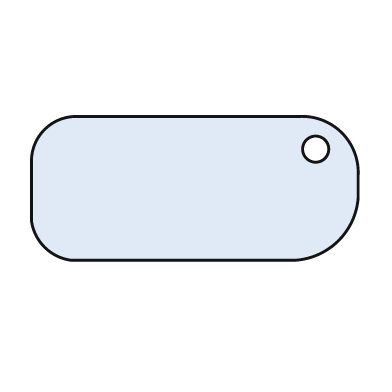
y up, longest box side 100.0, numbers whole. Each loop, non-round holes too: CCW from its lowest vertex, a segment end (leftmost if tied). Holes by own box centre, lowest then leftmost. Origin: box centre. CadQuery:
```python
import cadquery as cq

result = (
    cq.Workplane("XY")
    .moveTo(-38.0, -22.0)
    .lineTo(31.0, -22.0)
    .threePointArc((44.0, -16.0), (50.0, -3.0))
    .lineTo(50.0, 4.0)
    .threePointArc((45.0, 17.0), (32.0, 22.0))
    .lineTo(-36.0, 22.0)
    .threePointArc((-46.0, 18.0), (-50.0, 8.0))
    .lineTo(-50.0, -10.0)
    .threePointArc((-46.0, -18.0), (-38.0, -22.0))
    .close()
    .moveTo(37.0, 12.0)
    .circle(4.0)
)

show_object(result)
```